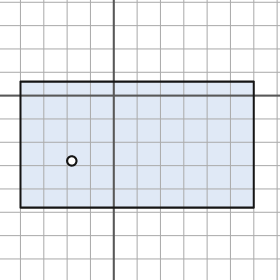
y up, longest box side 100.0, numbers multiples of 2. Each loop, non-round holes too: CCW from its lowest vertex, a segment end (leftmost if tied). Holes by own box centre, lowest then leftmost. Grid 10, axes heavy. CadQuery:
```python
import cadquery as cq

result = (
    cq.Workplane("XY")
    .moveTo(-40.0, -48.0)
    .lineTo(60.0, -48.0)
    .lineTo(60.0, 6.0)
    .lineTo(-40.0, 6.0)
    .close()
    .moveTo(-18.0, -28.0)
    .circle(2.0)
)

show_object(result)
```